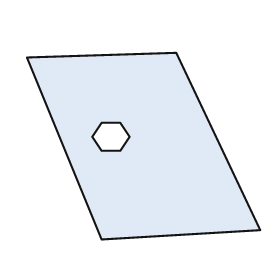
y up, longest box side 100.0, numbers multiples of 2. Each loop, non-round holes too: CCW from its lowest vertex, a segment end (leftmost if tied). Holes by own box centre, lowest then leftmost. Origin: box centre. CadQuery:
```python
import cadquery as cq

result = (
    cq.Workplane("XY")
    .moveTo(-18.0, -40.0)
    .lineTo(50.0, -36.0)
    .lineTo(14.0, 40.0)
    .lineTo(-50.0, 38.0)
    .close()
    .moveTo(-18.0, -2.0)
    .lineTo(-10.0, -2.0)
    .lineTo(-6.0, 4.0)
    .lineTo(-10.0, 10.0)
    .lineTo(-18.0, 10.0)
    .lineTo(-22.0, 4.0)
    .close()
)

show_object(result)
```